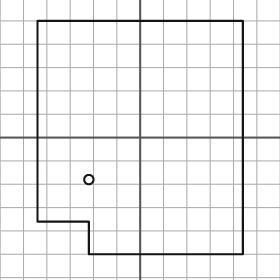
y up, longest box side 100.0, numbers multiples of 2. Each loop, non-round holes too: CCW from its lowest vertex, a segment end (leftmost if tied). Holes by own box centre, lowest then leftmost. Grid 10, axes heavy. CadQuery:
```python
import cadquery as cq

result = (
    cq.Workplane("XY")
    .moveTo(-22.0, -50.0)
    .lineTo(44.0, -50.0)
    .lineTo(44.0, 50.0)
    .lineTo(-44.0, 50.0)
    .lineTo(-44.0, -36.0)
    .lineTo(-22.0, -36.0)
    .close()
    .moveTo(-22.0, -18.0)
    .circle(2.0)
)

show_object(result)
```